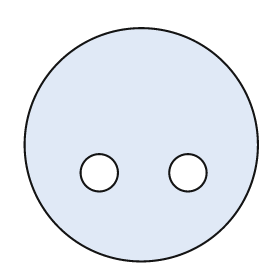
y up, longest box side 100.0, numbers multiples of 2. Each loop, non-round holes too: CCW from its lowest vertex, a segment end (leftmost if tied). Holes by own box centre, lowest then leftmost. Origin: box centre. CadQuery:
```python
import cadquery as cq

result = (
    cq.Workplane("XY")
    .moveTo(0.0, 0.0)
    .circle(50.0)
    .moveTo(-18.0, -12.0)
    .circle(8.0)
    .moveTo(20.0, -12.0)
    .circle(8.0)
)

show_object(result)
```